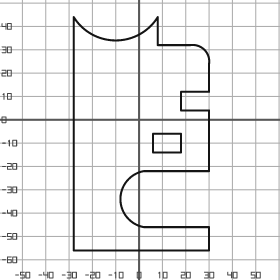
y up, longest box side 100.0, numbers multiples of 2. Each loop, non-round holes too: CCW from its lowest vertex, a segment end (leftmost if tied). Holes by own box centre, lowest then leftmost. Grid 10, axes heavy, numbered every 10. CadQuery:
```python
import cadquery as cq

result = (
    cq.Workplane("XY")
    .moveTo(-28.0, -56.0)
    .lineTo(30.0, -56.0)
    .lineTo(30.0, -46.0)
    .lineTo(2.0, -46.0)
    .threePointArc((-8.0, -34.0), (2.0, -22.0))
    .lineTo(30.0, -22.0)
    .lineTo(30.0, 4.0)
    .lineTo(18.0, 4.0)
    .lineTo(18.0, 12.0)
    .lineTo(30.0, 12.0)
    .lineTo(30.0, 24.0)
    .threePointArc((28.0, 30.0), (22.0, 32.0))
    .lineTo(8.0, 32.0)
    .lineTo(8.0, 44.0)
    .threePointArc((-10.0, 34.0), (-28.0, 44.0))
    .close()
    .moveTo(6.0, -14.0)
    .lineTo(18.0, -14.0)
    .lineTo(18.0, -6.0)
    .lineTo(6.0, -6.0)
    .close()
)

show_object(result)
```